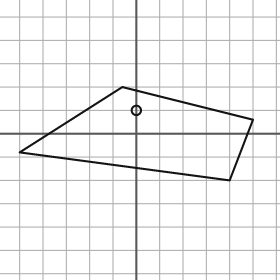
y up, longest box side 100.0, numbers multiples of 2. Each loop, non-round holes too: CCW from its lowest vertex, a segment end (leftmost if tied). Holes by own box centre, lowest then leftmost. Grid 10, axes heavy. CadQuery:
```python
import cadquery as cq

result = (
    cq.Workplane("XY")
    .moveTo(40.0, -20.0)
    .lineTo(50.0, 6.0)
    .lineTo(-6.0, 20.0)
    .lineTo(-50.0, -8.0)
    .close()
    .moveTo(0.0, 10.0)
    .circle(2.0)
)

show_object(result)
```